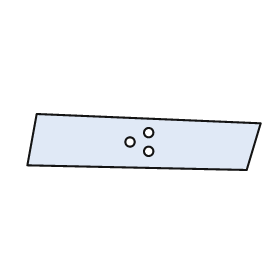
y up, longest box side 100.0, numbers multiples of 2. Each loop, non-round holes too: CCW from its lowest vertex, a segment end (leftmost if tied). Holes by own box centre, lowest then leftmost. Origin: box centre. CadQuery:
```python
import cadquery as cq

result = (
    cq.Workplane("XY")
    .moveTo(44.0, -12.0)
    .lineTo(50.0, 8.0)
    .lineTo(-46.0, 12.0)
    .lineTo(-50.0, -10.0)
    .close()
    .moveTo(2.0, -4.0)
    .circle(2.0)
    .moveTo(-6.0, 0.0)
    .circle(2.0)
    .moveTo(2.0, 4.0)
    .circle(2.0)
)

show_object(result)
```